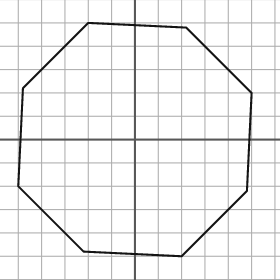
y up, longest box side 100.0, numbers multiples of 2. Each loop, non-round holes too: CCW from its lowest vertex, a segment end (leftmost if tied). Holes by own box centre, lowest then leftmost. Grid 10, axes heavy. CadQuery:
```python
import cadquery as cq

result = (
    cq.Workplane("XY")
    .moveTo(20.0, -50.0)
    .lineTo(48.0, -22.0)
    .lineTo(50.0, 20.0)
    .lineTo(22.0, 48.0)
    .lineTo(-20.0, 50.0)
    .lineTo(-48.0, 22.0)
    .lineTo(-50.0, -20.0)
    .lineTo(-22.0, -48.0)
    .close()
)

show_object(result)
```